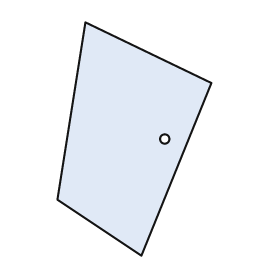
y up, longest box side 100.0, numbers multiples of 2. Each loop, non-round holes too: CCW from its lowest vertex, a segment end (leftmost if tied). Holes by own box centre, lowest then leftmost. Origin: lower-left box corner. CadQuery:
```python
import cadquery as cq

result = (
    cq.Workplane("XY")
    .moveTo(36.0, 0.0)
    .lineTo(66.0, 74.0)
    .lineTo(12.0, 100.0)
    .lineTo(0.0, 24.0)
    .close()
    .moveTo(46.0, 50.0)
    .circle(2.0)
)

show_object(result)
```